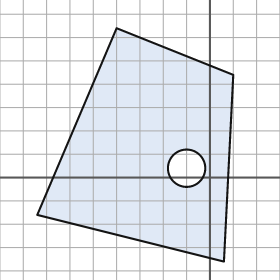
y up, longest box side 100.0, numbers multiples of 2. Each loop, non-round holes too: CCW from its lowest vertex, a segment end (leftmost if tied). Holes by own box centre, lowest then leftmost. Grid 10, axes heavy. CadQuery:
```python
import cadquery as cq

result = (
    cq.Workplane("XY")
    .moveTo(6.0, -36.0)
    .lineTo(10.0, 44.0)
    .lineTo(-40.0, 64.0)
    .lineTo(-74.0, -16.0)
    .close()
    .moveTo(-10.0, 4.0)
    .circle(8.0)
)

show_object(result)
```